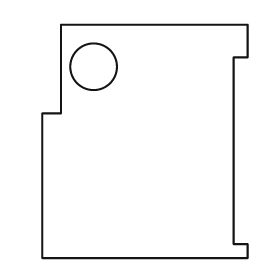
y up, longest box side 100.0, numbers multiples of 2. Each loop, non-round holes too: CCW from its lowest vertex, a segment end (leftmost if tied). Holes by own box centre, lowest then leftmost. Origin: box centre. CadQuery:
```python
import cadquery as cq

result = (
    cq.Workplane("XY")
    .moveTo(-44.0, -50.0)
    .lineTo(44.0, -50.0)
    .lineTo(44.0, -44.0)
    .lineTo(38.0, -44.0)
    .lineTo(38.0, 36.0)
    .lineTo(44.0, 36.0)
    .lineTo(44.0, 50.0)
    .lineTo(-36.0, 50.0)
    .lineTo(-36.0, 12.0)
    .lineTo(-44.0, 12.0)
    .close()
    .moveTo(-22.0, 32.0)
    .circle(10.0)
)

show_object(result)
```